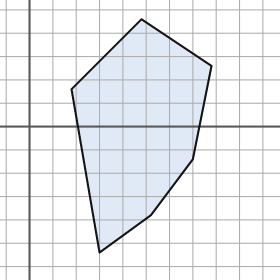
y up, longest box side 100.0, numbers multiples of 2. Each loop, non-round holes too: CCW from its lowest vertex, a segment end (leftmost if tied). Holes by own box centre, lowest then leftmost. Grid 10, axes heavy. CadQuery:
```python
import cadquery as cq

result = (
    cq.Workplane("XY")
    .moveTo(30.0, -54.0)
    .lineTo(52.0, -38.0)
    .lineTo(70.0, -14.0)
    .lineTo(78.0, 26.0)
    .lineTo(48.0, 46.0)
    .lineTo(18.0, 16.0)
    .close()
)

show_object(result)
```